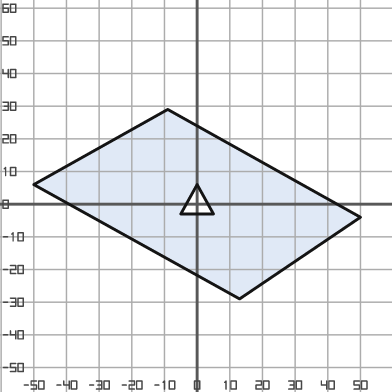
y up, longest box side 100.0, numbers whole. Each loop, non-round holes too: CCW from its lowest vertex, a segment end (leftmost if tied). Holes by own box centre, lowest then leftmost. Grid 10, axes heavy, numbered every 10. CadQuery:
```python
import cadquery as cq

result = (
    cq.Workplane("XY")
    .moveTo(13.0, -29.0)
    .lineTo(50.0, -4.0)
    .lineTo(-9.0, 29.0)
    .lineTo(-50.0, 6.0)
    .close()
    .moveTo(-5.0, -3.0)
    .lineTo(5.0, -3.0)
    .lineTo(0.0, 6.0)
    .close()
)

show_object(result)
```